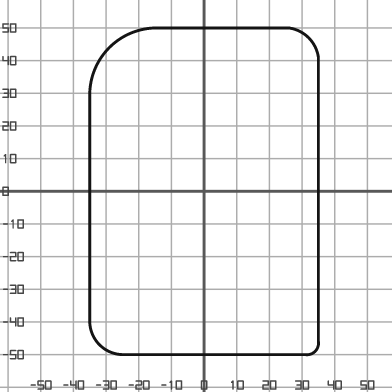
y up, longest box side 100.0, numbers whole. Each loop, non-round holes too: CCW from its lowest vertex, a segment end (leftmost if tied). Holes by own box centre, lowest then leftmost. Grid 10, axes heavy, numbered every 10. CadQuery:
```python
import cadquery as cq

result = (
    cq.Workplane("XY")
    .moveTo(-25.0, -50.0)
    .lineTo(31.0, -50.0)
    .threePointArc((34.0, -49.0), (35.0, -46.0))
    .lineTo(35.0, 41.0)
    .threePointArc((32.0, 47.0), (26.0, 50.0))
    .lineTo(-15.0, 50.0)
    .threePointArc((-29.0, 44.0), (-35.0, 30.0))
    .lineTo(-35.0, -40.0)
    .threePointArc((-32.0, -47.0), (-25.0, -50.0))
    .close()
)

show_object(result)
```